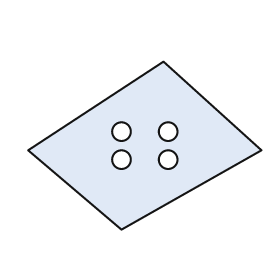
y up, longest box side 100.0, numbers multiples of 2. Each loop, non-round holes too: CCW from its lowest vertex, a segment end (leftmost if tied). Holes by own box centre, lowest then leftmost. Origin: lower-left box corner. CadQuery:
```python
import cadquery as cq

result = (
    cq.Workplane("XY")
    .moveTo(40.0, 0.0)
    .lineTo(100.0, 34.0)
    .lineTo(58.0, 72.0)
    .lineTo(0.0, 34.0)
    .close()
    .moveTo(40.0, 30.0)
    .circle(4.0)
    .moveTo(60.0, 30.0)
    .circle(4.0)
    .moveTo(40.0, 42.0)
    .circle(4.0)
    .moveTo(60.0, 42.0)
    .circle(4.0)
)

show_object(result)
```